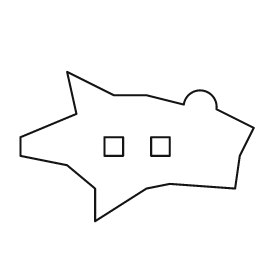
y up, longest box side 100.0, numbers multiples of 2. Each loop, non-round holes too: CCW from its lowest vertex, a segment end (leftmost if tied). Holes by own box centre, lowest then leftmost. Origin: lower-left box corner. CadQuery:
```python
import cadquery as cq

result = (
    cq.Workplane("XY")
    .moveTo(32.0, 0.0)
    .lineTo(54.0, 14.0)
    .lineTo(64.0, 16.0)
    .lineTo(92.0, 14.0)
    .lineTo(94.0, 28.0)
    .lineTo(100.0, 40.0)
    .lineTo(84.0, 48.0)
    .threePointArc((78.0, 56.0), (70.0, 50.0))
    .lineTo(54.0, 54.0)
    .lineTo(40.0, 54.0)
    .lineTo(20.0, 64.0)
    .lineTo(24.0, 46.0)
    .lineTo(0.0, 36.0)
    .lineTo(0.0, 28.0)
    .lineTo(20.0, 24.0)
    .lineTo(32.0, 14.0)
    .close()
    .moveTo(36.0, 28.0)
    .lineTo(44.0, 28.0)
    .lineTo(44.0, 36.0)
    .lineTo(36.0, 36.0)
    .close()
    .moveTo(56.0, 28.0)
    .lineTo(64.0, 28.0)
    .lineTo(64.0, 36.0)
    .lineTo(56.0, 36.0)
    .close()
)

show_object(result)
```